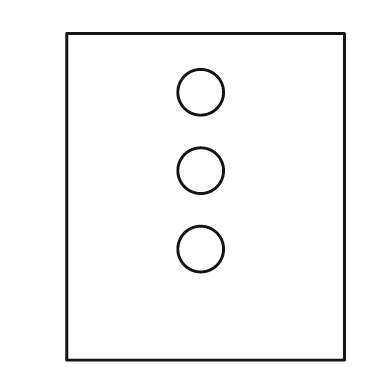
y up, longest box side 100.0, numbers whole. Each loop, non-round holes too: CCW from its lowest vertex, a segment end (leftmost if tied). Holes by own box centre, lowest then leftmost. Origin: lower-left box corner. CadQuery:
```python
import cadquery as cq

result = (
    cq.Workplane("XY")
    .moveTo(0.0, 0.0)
    .lineTo(85.0, 0.0)
    .lineTo(85.0, 100.0)
    .lineTo(0.0, 100.0)
    .close()
    .moveTo(41.0, 34.0)
    .circle(7.0)
    .moveTo(41.0, 58.0)
    .circle(7.0)
    .moveTo(41.0, 82.0)
    .circle(7.0)
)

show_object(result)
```